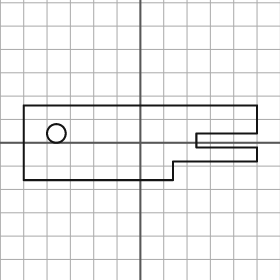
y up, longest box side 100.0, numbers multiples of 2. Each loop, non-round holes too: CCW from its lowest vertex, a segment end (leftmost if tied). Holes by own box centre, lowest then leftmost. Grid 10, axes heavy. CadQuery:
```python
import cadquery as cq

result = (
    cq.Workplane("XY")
    .moveTo(-50.0, -16.0)
    .lineTo(14.0, -16.0)
    .lineTo(14.0, -8.0)
    .lineTo(50.0, -8.0)
    .lineTo(50.0, -2.0)
    .lineTo(24.0, -2.0)
    .lineTo(24.0, 4.0)
    .lineTo(50.0, 4.0)
    .lineTo(50.0, 16.0)
    .lineTo(-50.0, 16.0)
    .close()
    .moveTo(-36.0, 4.0)
    .circle(4.0)
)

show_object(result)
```